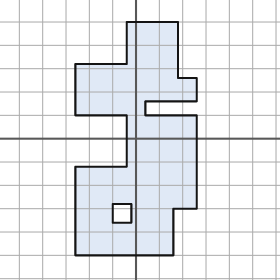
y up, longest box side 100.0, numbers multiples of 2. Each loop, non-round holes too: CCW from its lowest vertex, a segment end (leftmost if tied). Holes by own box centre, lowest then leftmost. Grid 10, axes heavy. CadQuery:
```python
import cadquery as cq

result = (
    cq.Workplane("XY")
    .moveTo(-26.0, -50.0)
    .lineTo(16.0, -50.0)
    .lineTo(16.0, -30.0)
    .lineTo(26.0, -30.0)
    .lineTo(26.0, 10.0)
    .lineTo(4.0, 10.0)
    .lineTo(4.0, 16.0)
    .lineTo(26.0, 16.0)
    .lineTo(26.0, 26.0)
    .lineTo(18.0, 26.0)
    .lineTo(18.0, 50.0)
    .lineTo(-4.0, 50.0)
    .lineTo(-4.0, 32.0)
    .lineTo(-26.0, 32.0)
    .lineTo(-26.0, 10.0)
    .lineTo(-4.0, 10.0)
    .lineTo(-4.0, -12.0)
    .lineTo(-26.0, -12.0)
    .close()
    .moveTo(-10.0, -36.0)
    .lineTo(-2.0, -36.0)
    .lineTo(-2.0, -28.0)
    .lineTo(-10.0, -28.0)
    .close()
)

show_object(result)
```